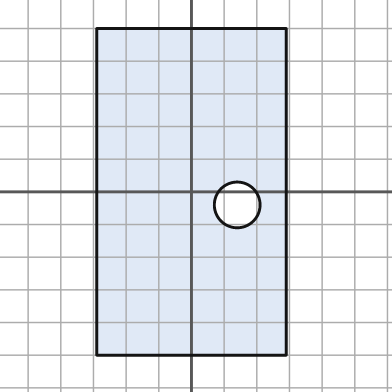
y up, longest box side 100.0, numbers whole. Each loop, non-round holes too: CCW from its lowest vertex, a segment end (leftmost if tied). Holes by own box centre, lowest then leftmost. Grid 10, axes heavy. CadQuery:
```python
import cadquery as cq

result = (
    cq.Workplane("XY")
    .moveTo(-29.0, -50.0)
    .lineTo(29.0, -50.0)
    .lineTo(29.0, 50.0)
    .lineTo(-29.0, 50.0)
    .close()
    .moveTo(14.0, -4.0)
    .circle(7.0)
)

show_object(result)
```